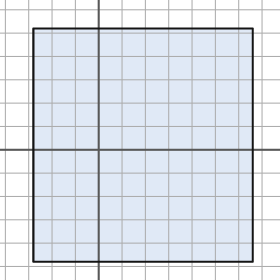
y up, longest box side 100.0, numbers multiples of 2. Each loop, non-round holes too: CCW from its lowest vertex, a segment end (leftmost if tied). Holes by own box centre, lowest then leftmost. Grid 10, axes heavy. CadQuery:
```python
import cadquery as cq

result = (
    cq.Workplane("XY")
    .moveTo(-28.0, -48.0)
    .lineTo(66.0, -48.0)
    .lineTo(66.0, 52.0)
    .lineTo(-28.0, 52.0)
    .close()
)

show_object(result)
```